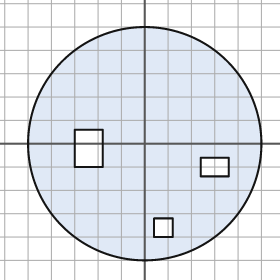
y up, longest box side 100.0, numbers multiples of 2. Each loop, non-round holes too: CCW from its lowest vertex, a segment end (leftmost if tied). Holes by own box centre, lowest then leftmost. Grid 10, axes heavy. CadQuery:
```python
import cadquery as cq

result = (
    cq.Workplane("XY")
    .moveTo(0.0, 0.0)
    .circle(50.0)
    .moveTo(4.0, -40.0)
    .lineTo(12.0, -40.0)
    .lineTo(12.0, -32.0)
    .lineTo(4.0, -32.0)
    .close()
    .moveTo(24.0, -14.0)
    .lineTo(36.0, -14.0)
    .lineTo(36.0, -6.0)
    .lineTo(24.0, -6.0)
    .close()
    .moveTo(-30.0, -10.0)
    .lineTo(-18.0, -10.0)
    .lineTo(-18.0, 6.0)
    .lineTo(-30.0, 6.0)
    .close()
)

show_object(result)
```